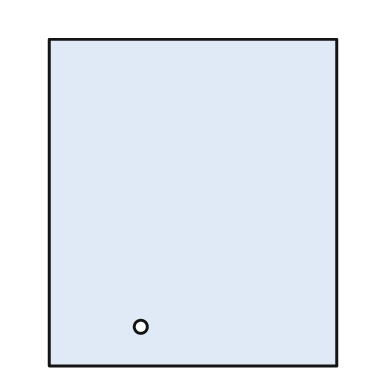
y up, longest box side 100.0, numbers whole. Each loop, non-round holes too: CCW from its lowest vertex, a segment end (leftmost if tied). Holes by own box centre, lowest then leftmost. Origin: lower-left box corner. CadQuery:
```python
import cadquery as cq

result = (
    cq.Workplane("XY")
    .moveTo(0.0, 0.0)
    .lineTo(88.0, 0.0)
    .lineTo(88.0, 100.0)
    .lineTo(0.0, 100.0)
    .close()
    .moveTo(28.0, 12.0)
    .circle(2.0)
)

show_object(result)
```